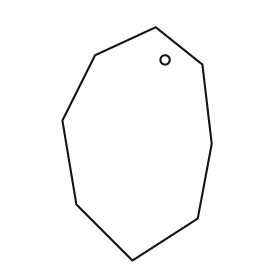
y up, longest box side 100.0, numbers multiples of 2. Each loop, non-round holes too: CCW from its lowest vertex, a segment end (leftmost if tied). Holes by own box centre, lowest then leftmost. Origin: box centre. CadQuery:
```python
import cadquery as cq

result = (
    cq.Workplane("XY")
    .moveTo(-2.0, -50.0)
    .lineTo(26.0, -32.0)
    .lineTo(32.0, 0.0)
    .lineTo(28.0, 34.0)
    .lineTo(8.0, 50.0)
    .lineTo(-18.0, 38.0)
    .lineTo(-32.0, 10.0)
    .lineTo(-26.0, -26.0)
    .close()
    .moveTo(12.0, 36.0)
    .circle(2.0)
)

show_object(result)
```